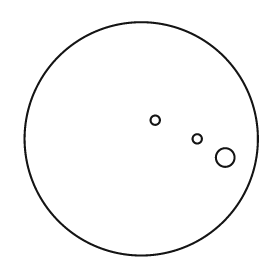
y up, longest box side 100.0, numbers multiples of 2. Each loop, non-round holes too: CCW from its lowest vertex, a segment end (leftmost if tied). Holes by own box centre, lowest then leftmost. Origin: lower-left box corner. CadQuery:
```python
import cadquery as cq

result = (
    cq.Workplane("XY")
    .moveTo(50.0, 50.0)
    .circle(50.0)
    .moveTo(86.0, 42.0)
    .circle(4.0)
    .moveTo(74.0, 50.0)
    .circle(2.0)
    .moveTo(56.0, 58.0)
    .circle(2.0)
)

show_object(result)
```